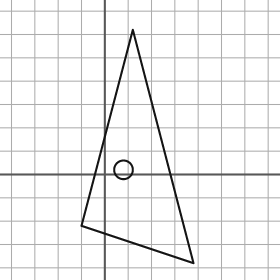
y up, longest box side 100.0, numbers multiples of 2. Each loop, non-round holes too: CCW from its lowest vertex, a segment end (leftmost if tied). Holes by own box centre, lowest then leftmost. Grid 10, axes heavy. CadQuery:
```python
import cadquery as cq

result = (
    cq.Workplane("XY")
    .moveTo(38.0, -38.0)
    .lineTo(12.0, 62.0)
    .lineTo(-10.0, -22.0)
    .close()
    .moveTo(8.0, 2.0)
    .circle(4.0)
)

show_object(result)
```